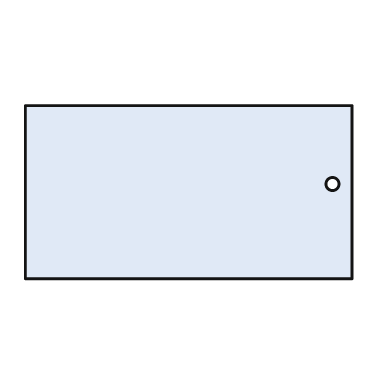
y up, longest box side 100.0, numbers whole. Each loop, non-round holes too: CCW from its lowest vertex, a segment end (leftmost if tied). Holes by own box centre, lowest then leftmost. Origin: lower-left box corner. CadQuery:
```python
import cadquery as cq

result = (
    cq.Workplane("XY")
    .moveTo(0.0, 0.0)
    .lineTo(100.0, 0.0)
    .lineTo(100.0, 53.0)
    .lineTo(0.0, 53.0)
    .close()
    .moveTo(94.0, 29.0)
    .circle(2.0)
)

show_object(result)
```